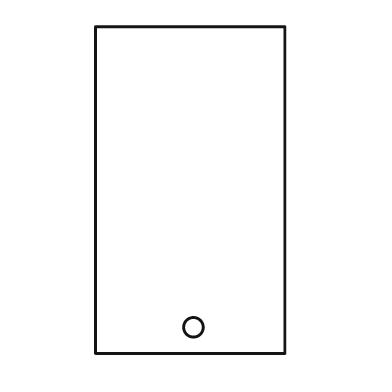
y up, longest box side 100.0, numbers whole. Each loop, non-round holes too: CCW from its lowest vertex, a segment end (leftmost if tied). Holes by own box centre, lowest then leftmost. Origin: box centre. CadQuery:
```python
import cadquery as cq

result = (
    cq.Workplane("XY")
    .moveTo(-29.0, -50.0)
    .lineTo(29.0, -50.0)
    .lineTo(29.0, 50.0)
    .lineTo(-29.0, 50.0)
    .close()
    .moveTo(1.0, -42.0)
    .circle(3.0)
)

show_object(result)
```